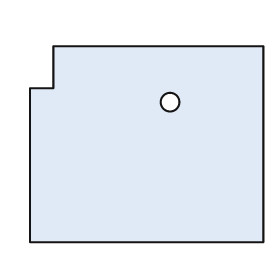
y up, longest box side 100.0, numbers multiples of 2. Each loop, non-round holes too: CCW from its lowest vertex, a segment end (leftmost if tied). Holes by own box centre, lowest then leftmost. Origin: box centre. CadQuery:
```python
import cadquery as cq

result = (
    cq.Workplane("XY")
    .moveTo(-50.0, -42.0)
    .lineTo(50.0, -42.0)
    .lineTo(50.0, 42.0)
    .lineTo(-40.0, 42.0)
    .lineTo(-40.0, 24.0)
    .lineTo(-50.0, 24.0)
    .close()
    .moveTo(10.0, 18.0)
    .circle(4.0)
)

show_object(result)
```